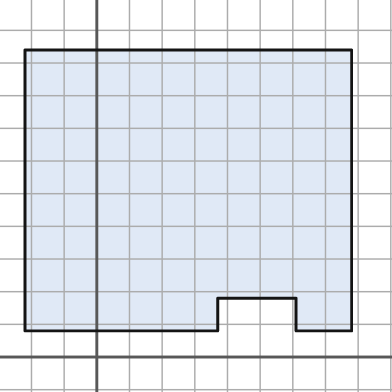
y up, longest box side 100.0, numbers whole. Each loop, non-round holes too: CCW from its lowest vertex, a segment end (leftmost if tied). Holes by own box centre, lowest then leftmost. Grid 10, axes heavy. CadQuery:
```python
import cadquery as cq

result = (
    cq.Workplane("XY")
    .moveTo(-22.0, 8.0)
    .lineTo(37.0, 8.0)
    .lineTo(37.0, 18.0)
    .lineTo(61.0, 18.0)
    .lineTo(61.0, 8.0)
    .lineTo(78.0, 8.0)
    .lineTo(78.0, 94.0)
    .lineTo(-22.0, 94.0)
    .close()
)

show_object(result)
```